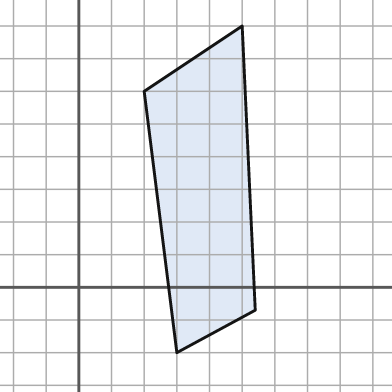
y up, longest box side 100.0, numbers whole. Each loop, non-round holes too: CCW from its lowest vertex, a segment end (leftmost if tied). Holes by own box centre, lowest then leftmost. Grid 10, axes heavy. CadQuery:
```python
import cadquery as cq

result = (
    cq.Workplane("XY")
    .moveTo(30.0, -20.0)
    .lineTo(54.0, -7.0)
    .lineTo(50.0, 80.0)
    .lineTo(20.0, 60.0)
    .close()
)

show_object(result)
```